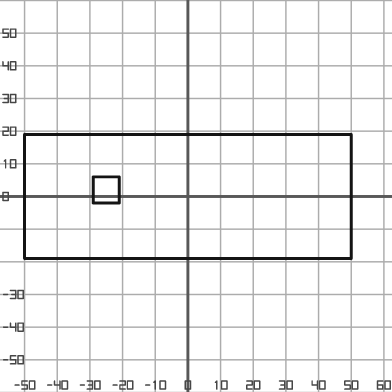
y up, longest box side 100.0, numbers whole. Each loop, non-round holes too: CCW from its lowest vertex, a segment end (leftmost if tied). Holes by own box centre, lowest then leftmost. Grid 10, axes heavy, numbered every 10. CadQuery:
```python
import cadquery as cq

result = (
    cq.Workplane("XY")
    .moveTo(-50.0, -19.0)
    .lineTo(50.0, -19.0)
    .lineTo(50.0, 19.0)
    .lineTo(-50.0, 19.0)
    .close()
    .moveTo(-29.0, -2.0)
    .lineTo(-21.0, -2.0)
    .lineTo(-21.0, 6.0)
    .lineTo(-29.0, 6.0)
    .close()
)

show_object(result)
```